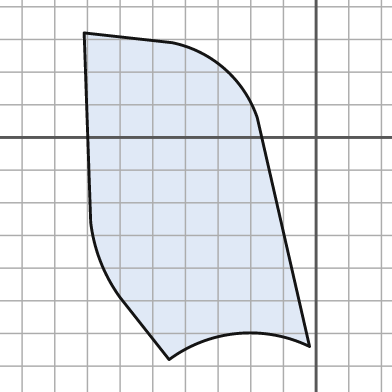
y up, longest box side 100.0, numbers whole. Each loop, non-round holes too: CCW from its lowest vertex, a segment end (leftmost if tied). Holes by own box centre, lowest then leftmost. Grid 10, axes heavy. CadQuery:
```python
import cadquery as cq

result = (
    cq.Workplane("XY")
    .moveTo(-45.0, -68.0)
    .threePointArc((-24.0, -60.0), (-2.0, -64.0))
    .lineTo(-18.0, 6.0)
    .threePointArc((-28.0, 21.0), (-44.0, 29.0))
    .lineTo(-71.0, 32.0)
    .lineTo(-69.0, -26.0)
    .threePointArc((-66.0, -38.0), (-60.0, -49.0))
    .close()
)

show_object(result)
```